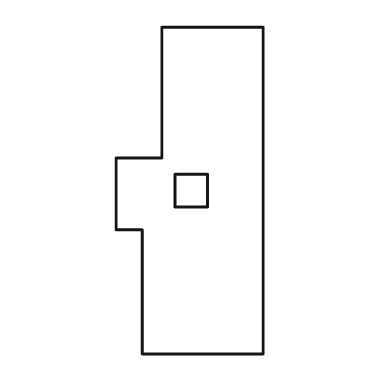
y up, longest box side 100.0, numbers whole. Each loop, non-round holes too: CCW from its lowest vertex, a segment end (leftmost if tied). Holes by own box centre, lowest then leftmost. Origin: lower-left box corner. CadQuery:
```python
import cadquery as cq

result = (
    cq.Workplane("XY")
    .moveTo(8.0, 0.0)
    .lineTo(45.0, 0.0)
    .lineTo(45.0, 100.0)
    .lineTo(14.0, 100.0)
    .lineTo(14.0, 60.0)
    .lineTo(0.0, 60.0)
    .lineTo(0.0, 38.0)
    .lineTo(8.0, 38.0)
    .close()
    .moveTo(18.0, 45.0)
    .lineTo(28.0, 45.0)
    .lineTo(28.0, 55.0)
    .lineTo(18.0, 55.0)
    .close()
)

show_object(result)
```